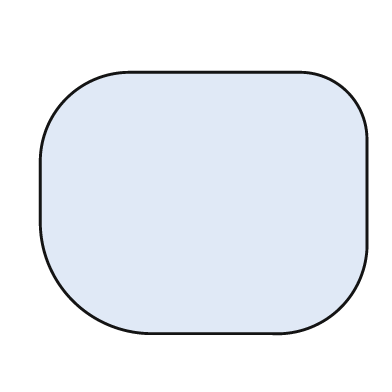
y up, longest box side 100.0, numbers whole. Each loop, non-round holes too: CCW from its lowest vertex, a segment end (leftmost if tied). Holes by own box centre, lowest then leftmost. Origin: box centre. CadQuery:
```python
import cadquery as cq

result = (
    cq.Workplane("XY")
    .moveTo(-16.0, -40.0)
    .lineTo(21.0, -40.0)
    .threePointArc((42.0, -32.0), (50.0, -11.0))
    .lineTo(50.0, 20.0)
    .threePointArc((44.0, 34.0), (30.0, 40.0))
    .lineTo(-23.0, 40.0)
    .threePointArc((-42.0, 32.0), (-50.0, 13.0))
    .lineTo(-50.0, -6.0)
    .threePointArc((-40.0, -30.0), (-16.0, -40.0))
    .close()
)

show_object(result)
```